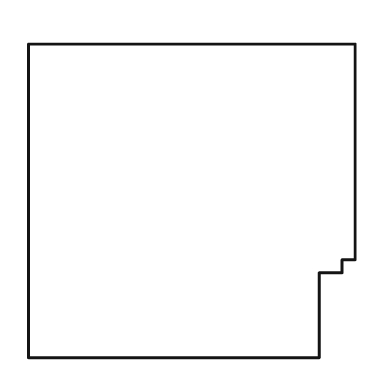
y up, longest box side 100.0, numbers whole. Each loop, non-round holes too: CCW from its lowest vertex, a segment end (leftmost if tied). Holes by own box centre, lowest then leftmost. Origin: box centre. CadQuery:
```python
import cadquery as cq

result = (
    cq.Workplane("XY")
    .moveTo(-50.0, -48.0)
    .lineTo(39.0, -48.0)
    .lineTo(39.0, -22.0)
    .lineTo(46.0, -22.0)
    .lineTo(46.0, -18.0)
    .lineTo(50.0, -18.0)
    .lineTo(50.0, 48.0)
    .lineTo(-50.0, 48.0)
    .close()
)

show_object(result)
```